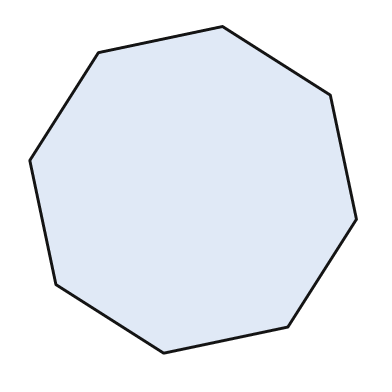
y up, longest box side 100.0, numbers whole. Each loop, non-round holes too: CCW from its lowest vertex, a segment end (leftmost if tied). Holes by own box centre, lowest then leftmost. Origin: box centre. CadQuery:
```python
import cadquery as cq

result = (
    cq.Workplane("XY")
    .moveTo(-9.0, -50.0)
    .lineTo(29.0, -42.0)
    .lineTo(50.0, -9.0)
    .lineTo(42.0, 29.0)
    .lineTo(9.0, 50.0)
    .lineTo(-29.0, 42.0)
    .lineTo(-50.0, 9.0)
    .lineTo(-42.0, -29.0)
    .close()
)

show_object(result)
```